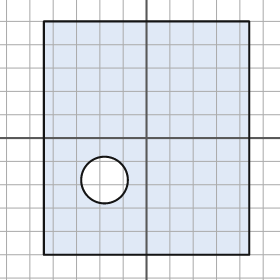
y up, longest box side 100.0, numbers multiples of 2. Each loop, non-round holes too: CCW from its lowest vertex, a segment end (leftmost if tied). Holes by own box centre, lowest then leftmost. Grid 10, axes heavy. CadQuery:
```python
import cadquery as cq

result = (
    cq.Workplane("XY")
    .moveTo(-44.0, -50.0)
    .lineTo(44.0, -50.0)
    .lineTo(44.0, 50.0)
    .lineTo(-44.0, 50.0)
    .close()
    .moveTo(-18.0, -18.0)
    .circle(10.0)
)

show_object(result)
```